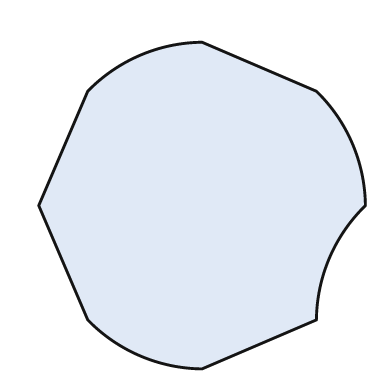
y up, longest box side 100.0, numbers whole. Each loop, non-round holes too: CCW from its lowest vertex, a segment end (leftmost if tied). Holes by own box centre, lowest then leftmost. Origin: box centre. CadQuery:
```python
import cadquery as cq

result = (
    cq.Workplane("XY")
    .moveTo(0.0, -50.0)
    .lineTo(35.0, -35.0)
    .threePointArc((39.0, -16.0), (50.0, 0.0))
    .threePointArc((46.0, 19.0), (35.0, 35.0))
    .lineTo(0.0, 50.0)
    .threePointArc((-19.0, 46.0), (-35.0, 35.0))
    .lineTo(-50.0, 0.0)
    .lineTo(-35.0, -35.0)
    .threePointArc((-19.0, -46.0), (0.0, -50.0))
    .close()
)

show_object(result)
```